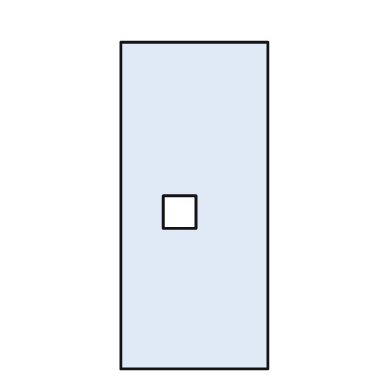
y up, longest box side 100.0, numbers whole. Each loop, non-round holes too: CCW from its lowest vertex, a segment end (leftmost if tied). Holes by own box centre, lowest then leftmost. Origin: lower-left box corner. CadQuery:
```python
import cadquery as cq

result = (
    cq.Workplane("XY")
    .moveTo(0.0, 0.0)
    .lineTo(45.0, 0.0)
    .lineTo(45.0, 100.0)
    .lineTo(0.0, 100.0)
    .close()
    .moveTo(13.0, 43.0)
    .lineTo(23.0, 43.0)
    .lineTo(23.0, 53.0)
    .lineTo(13.0, 53.0)
    .close()
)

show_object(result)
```